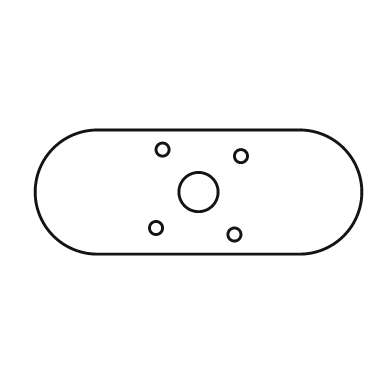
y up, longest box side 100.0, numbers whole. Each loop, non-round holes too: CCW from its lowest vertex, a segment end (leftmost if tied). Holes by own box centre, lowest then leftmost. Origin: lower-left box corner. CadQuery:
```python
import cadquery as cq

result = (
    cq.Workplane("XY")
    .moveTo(19.0, 0.0)
    .lineTo(81.0, 0.0)
    .threePointArc((100.0, 19.0), (81.0, 38.0))
    .lineTo(19.0, 38.0)
    .threePointArc((0.0, 19.0), (19.0, 0.0))
    .close()
    .moveTo(61.0, 6.0)
    .circle(2.0)
    .moveTo(37.0, 8.0)
    .circle(2.0)
    .moveTo(50.0, 19.0)
    .circle(6.0)
    .moveTo(63.0, 30.0)
    .circle(2.0)
    .moveTo(39.0, 32.0)
    .circle(2.0)
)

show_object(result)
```